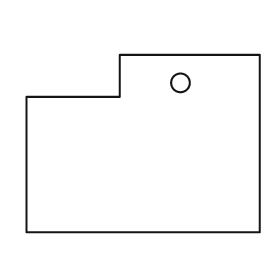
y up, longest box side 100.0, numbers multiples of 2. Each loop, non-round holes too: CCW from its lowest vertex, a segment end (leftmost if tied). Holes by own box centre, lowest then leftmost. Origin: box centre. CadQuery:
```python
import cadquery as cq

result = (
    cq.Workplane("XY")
    .moveTo(-50.0, -38.0)
    .lineTo(50.0, -38.0)
    .lineTo(50.0, 38.0)
    .lineTo(-10.0, 38.0)
    .lineTo(-10.0, 20.0)
    .lineTo(-50.0, 20.0)
    .close()
    .moveTo(16.0, 26.0)
    .circle(4.0)
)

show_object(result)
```